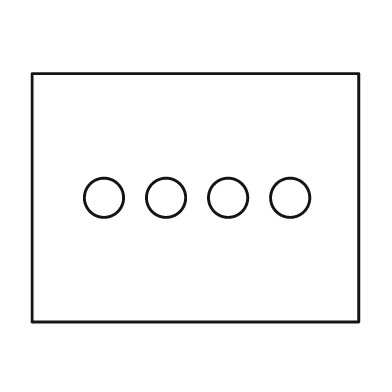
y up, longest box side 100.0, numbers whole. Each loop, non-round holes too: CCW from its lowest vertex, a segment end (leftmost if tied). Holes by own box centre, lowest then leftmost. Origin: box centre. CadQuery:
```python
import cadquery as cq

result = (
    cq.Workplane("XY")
    .moveTo(-50.0, -38.0)
    .lineTo(50.0, -38.0)
    .lineTo(50.0, 38.0)
    .lineTo(-50.0, 38.0)
    .close()
    .moveTo(-28.0, 0.0)
    .circle(6.0)
    .moveTo(-9.0, 0.0)
    .circle(6.0)
    .moveTo(10.0, 0.0)
    .circle(6.0)
    .moveTo(29.0, 0.0)
    .circle(6.0)
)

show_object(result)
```